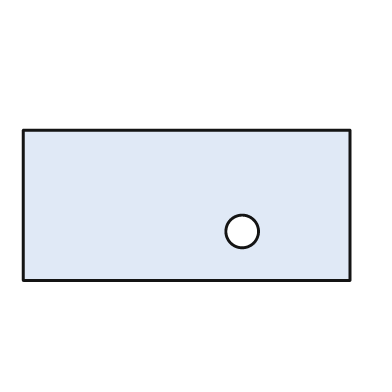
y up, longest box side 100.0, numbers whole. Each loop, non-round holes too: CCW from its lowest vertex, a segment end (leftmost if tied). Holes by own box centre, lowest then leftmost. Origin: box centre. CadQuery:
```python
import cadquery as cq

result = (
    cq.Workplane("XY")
    .moveTo(-50.0, -23.0)
    .lineTo(50.0, -23.0)
    .lineTo(50.0, 23.0)
    .lineTo(-50.0, 23.0)
    .close()
    .moveTo(17.0, -8.0)
    .circle(5.0)
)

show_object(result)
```